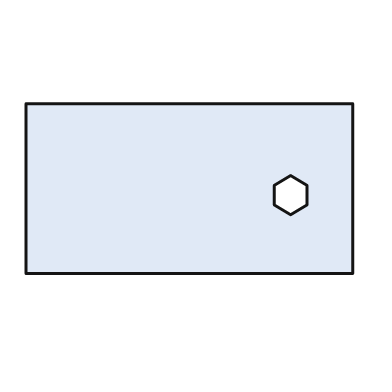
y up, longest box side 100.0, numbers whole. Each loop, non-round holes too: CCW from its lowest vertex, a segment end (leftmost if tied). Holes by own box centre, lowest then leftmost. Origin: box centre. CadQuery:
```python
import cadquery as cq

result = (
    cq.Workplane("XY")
    .moveTo(-50.0, -26.0)
    .lineTo(50.0, -26.0)
    .lineTo(50.0, 26.0)
    .lineTo(-50.0, 26.0)
    .close()
    .moveTo(31.0, -8.0)
    .lineTo(36.0, -5.0)
    .lineTo(36.0, 1.0)
    .lineTo(31.0, 4.0)
    .lineTo(26.0, 1.0)
    .lineTo(26.0, -5.0)
    .close()
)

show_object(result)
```